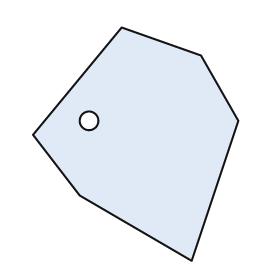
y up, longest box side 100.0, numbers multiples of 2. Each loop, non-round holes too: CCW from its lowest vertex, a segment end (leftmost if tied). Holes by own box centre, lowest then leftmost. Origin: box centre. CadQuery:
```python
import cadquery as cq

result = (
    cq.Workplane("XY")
    .moveTo(24.0, -50.0)
    .lineTo(44.0, 10.0)
    .lineTo(28.0, 38.0)
    .lineTo(-6.0, 50.0)
    .lineTo(-44.0, 4.0)
    .lineTo(-24.0, -22.0)
    .close()
    .moveTo(-20.0, 10.0)
    .circle(4.0)
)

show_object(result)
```